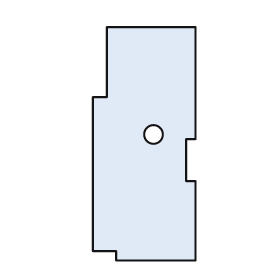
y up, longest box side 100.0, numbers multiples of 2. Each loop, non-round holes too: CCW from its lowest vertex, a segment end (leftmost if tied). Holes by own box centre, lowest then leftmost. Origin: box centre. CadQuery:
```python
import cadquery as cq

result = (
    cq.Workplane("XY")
    .moveTo(-12.0, -50.0)
    .lineTo(22.0, -50.0)
    .lineTo(22.0, -16.0)
    .lineTo(18.0, -16.0)
    .lineTo(18.0, 2.0)
    .lineTo(22.0, 2.0)
    .lineTo(22.0, 50.0)
    .lineTo(-16.0, 50.0)
    .lineTo(-16.0, 20.0)
    .lineTo(-22.0, 20.0)
    .lineTo(-22.0, -46.0)
    .lineTo(-12.0, -46.0)
    .close()
    .moveTo(4.0, 4.0)
    .circle(4.0)
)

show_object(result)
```